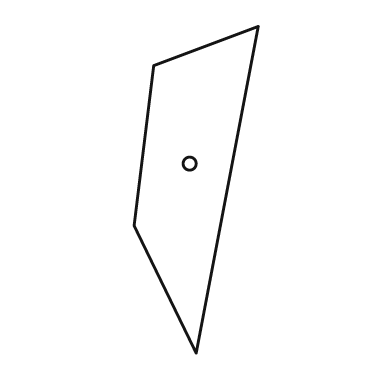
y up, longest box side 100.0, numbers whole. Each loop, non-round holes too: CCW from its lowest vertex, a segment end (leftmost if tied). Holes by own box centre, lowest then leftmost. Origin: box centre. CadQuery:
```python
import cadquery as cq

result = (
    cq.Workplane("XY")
    .moveTo(0.0, -50.0)
    .lineTo(19.0, 50.0)
    .lineTo(-13.0, 38.0)
    .lineTo(-19.0, -11.0)
    .close()
    .moveTo(-2.0, 8.0)
    .circle(2.0)
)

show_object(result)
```